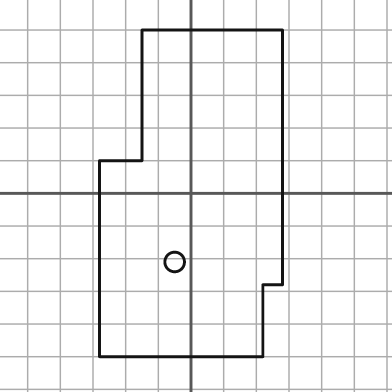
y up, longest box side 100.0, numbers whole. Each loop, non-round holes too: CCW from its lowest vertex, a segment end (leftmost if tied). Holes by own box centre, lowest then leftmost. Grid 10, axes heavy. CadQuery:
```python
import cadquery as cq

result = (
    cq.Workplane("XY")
    .moveTo(-28.0, -50.0)
    .lineTo(22.0, -50.0)
    .lineTo(22.0, -28.0)
    .lineTo(28.0, -28.0)
    .lineTo(28.0, 50.0)
    .lineTo(-15.0, 50.0)
    .lineTo(-15.0, 10.0)
    .lineTo(-28.0, 10.0)
    .close()
    .moveTo(-5.0, -21.0)
    .circle(3.0)
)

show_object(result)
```